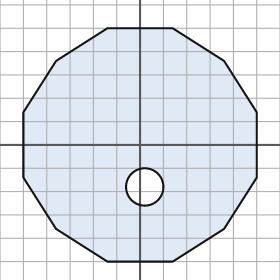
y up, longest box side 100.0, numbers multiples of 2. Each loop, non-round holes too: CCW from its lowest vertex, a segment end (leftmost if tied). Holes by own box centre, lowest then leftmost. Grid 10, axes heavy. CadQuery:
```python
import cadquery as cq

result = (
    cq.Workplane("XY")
    .moveTo(-14.0, -50.0)
    .lineTo(14.0, -50.0)
    .lineTo(36.0, -36.0)
    .lineTo(50.0, -14.0)
    .lineTo(50.0, 14.0)
    .lineTo(36.0, 36.0)
    .lineTo(14.0, 50.0)
    .lineTo(-14.0, 50.0)
    .lineTo(-36.0, 36.0)
    .lineTo(-50.0, 14.0)
    .lineTo(-50.0, -14.0)
    .lineTo(-36.0, -36.0)
    .close()
    .moveTo(2.0, -18.0)
    .circle(8.0)
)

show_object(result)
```